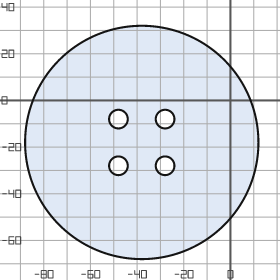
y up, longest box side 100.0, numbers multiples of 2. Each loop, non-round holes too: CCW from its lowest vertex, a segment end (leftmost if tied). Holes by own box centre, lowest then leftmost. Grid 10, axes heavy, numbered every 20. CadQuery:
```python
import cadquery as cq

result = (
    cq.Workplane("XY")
    .moveTo(-38.0, -18.0)
    .circle(50.0)
    .moveTo(-48.0, -28.0)
    .circle(4.0)
    .moveTo(-28.0, -28.0)
    .circle(4.0)
    .moveTo(-48.0, -8.0)
    .circle(4.0)
    .moveTo(-28.0, -8.0)
    .circle(4.0)
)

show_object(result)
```